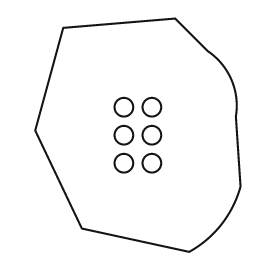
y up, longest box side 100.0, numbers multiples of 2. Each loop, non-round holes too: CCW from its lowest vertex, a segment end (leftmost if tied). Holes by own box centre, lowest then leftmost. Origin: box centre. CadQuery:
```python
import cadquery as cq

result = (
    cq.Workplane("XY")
    .moveTo(22.0, -50.0)
    .threePointArc((36.0, -38.0), (44.0, -22.0))
    .lineTo(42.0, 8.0)
    .threePointArc((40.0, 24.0), (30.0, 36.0))
    .lineTo(16.0, 50.0)
    .lineTo(-32.0, 46.0)
    .lineTo(-44.0, 2.0)
    .lineTo(-24.0, -40.0)
    .close()
    .moveTo(-6.0, -12.0)
    .circle(4.0)
    .moveTo(6.0, -12.0)
    .circle(4.0)
    .moveTo(-6.0, 0.0)
    .circle(4.0)
    .moveTo(6.0, 0.0)
    .circle(4.0)
    .moveTo(-6.0, 12.0)
    .circle(4.0)
    .moveTo(6.0, 12.0)
    .circle(4.0)
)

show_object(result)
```